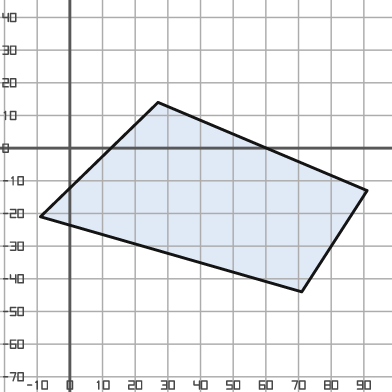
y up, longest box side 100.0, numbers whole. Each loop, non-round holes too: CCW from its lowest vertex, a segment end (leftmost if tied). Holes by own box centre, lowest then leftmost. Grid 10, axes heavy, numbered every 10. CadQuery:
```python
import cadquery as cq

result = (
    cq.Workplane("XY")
    .moveTo(71.0, -44.0)
    .lineTo(91.0, -13.0)
    .lineTo(27.0, 14.0)
    .lineTo(-9.0, -21.0)
    .close()
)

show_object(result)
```